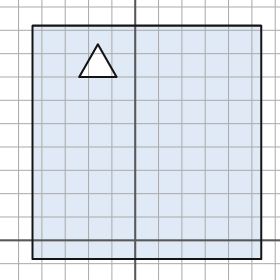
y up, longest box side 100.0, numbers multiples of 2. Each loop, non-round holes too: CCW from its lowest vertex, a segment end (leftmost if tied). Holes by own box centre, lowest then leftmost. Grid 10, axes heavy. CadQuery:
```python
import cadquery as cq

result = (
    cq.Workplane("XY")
    .moveTo(-44.0, -8.0)
    .lineTo(54.0, -8.0)
    .lineTo(54.0, 92.0)
    .lineTo(-44.0, 92.0)
    .close()
    .moveTo(-24.0, 70.0)
    .lineTo(-8.0, 70.0)
    .lineTo(-16.0, 84.0)
    .close()
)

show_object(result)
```